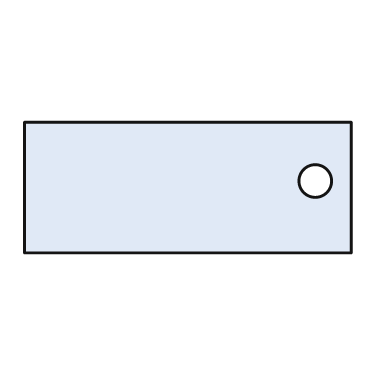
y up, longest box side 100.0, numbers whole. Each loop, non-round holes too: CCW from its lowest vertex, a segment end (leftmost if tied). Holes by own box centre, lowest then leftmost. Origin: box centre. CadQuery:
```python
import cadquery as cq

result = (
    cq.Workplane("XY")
    .moveTo(-50.0, -20.0)
    .lineTo(50.0, -20.0)
    .lineTo(50.0, 20.0)
    .lineTo(-50.0, 20.0)
    .close()
    .moveTo(39.0, 2.0)
    .circle(5.0)
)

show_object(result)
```